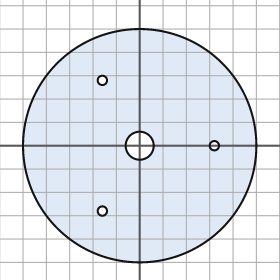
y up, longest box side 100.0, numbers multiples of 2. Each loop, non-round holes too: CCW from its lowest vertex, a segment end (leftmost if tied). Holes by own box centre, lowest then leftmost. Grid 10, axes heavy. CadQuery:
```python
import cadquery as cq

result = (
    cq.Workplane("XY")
    .moveTo(0.0, 0.0)
    .circle(50.0)
    .moveTo(-16.0, -28.0)
    .circle(2.0)
    .moveTo(0.0, 0.0)
    .circle(6.0)
    .moveTo(32.0, 0.0)
    .circle(2.0)
    .moveTo(-16.0, 28.0)
    .circle(2.0)
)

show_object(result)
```